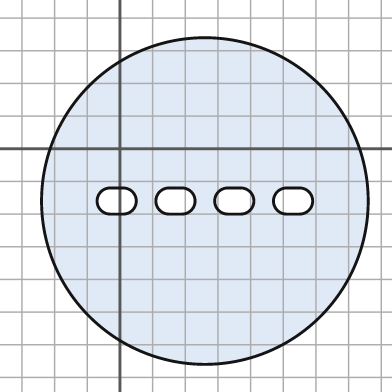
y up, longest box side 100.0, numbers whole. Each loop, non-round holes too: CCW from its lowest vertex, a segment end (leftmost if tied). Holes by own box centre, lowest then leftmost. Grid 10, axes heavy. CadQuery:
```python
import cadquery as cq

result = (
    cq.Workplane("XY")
    .moveTo(26.0, -16.0)
    .circle(50.0)
    .moveTo(-3.0, -20.0)
    .lineTo(1.0, -20.0)
    .threePointArc((5.0, -16.0), (1.0, -12.0))
    .lineTo(-3.0, -12.0)
    .threePointArc((-7.0, -16.0), (-3.0, -20.0))
    .close()
    .moveTo(15.0, -20.0)
    .lineTo(19.0, -20.0)
    .threePointArc((23.0, -16.0), (19.0, -12.0))
    .lineTo(15.0, -12.0)
    .threePointArc((11.0, -16.0), (15.0, -20.0))
    .close()
    .moveTo(33.0, -20.0)
    .lineTo(37.0, -20.0)
    .threePointArc((41.0, -16.0), (37.0, -12.0))
    .lineTo(33.0, -12.0)
    .threePointArc((29.0, -16.0), (33.0, -20.0))
    .close()
    .moveTo(51.0, -20.0)
    .lineTo(55.0, -20.0)
    .threePointArc((59.0, -16.0), (55.0, -12.0))
    .lineTo(51.0, -12.0)
    .threePointArc((47.0, -16.0), (51.0, -20.0))
    .close()
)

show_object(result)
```